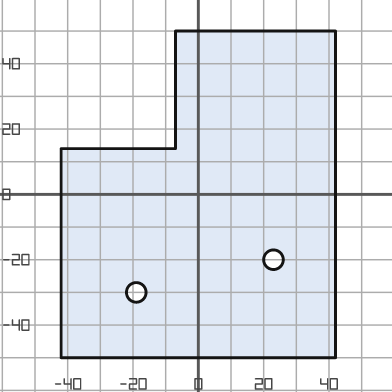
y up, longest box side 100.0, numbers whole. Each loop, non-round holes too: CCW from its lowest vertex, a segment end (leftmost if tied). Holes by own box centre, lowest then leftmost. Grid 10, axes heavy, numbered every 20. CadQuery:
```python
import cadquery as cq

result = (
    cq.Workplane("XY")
    .moveTo(-42.0, -50.0)
    .lineTo(42.0, -50.0)
    .lineTo(42.0, 50.0)
    .lineTo(-7.0, 50.0)
    .lineTo(-7.0, 14.0)
    .lineTo(-42.0, 14.0)
    .close()
    .moveTo(-19.0, -30.0)
    .circle(3.0)
    .moveTo(23.0, -20.0)
    .circle(3.0)
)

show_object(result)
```